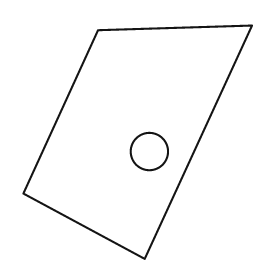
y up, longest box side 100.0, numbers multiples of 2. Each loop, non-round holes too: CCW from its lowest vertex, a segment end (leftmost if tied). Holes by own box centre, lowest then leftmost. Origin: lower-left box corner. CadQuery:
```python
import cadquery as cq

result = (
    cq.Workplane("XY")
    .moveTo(52.0, 0.0)
    .lineTo(98.0, 100.0)
    .lineTo(32.0, 98.0)
    .lineTo(0.0, 28.0)
    .close()
    .moveTo(54.0, 46.0)
    .circle(8.0)
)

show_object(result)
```